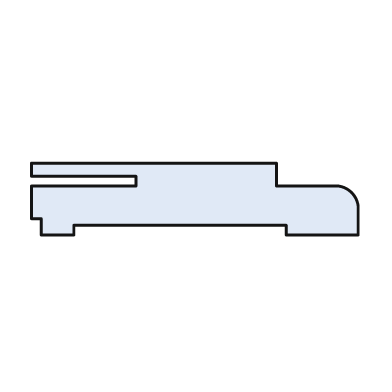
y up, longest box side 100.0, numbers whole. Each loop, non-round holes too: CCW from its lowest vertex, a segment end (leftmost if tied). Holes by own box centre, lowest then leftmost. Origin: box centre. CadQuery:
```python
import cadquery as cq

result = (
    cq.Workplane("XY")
    .moveTo(-47.0, -11.0)
    .lineTo(-37.0, -11.0)
    .lineTo(-37.0, -8.0)
    .lineTo(28.0, -8.0)
    .lineTo(28.0, -11.0)
    .lineTo(50.0, -11.0)
    .lineTo(50.0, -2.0)
    .threePointArc((48.0, 2.0), (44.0, 4.0))
    .lineTo(25.0, 4.0)
    .lineTo(25.0, 11.0)
    .lineTo(-50.0, 11.0)
    .lineTo(-50.0, 7.0)
    .lineTo(-18.0, 7.0)
    .lineTo(-18.0, 4.0)
    .lineTo(-50.0, 4.0)
    .lineTo(-50.0, -6.0)
    .lineTo(-47.0, -6.0)
    .close()
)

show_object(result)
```